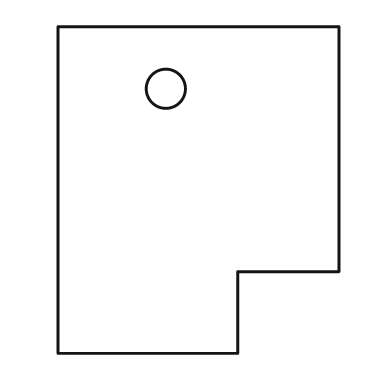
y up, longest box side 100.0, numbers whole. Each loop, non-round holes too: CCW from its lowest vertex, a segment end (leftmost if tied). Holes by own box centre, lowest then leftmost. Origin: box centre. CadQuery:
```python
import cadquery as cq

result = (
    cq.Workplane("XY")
    .moveTo(-43.0, -50.0)
    .lineTo(12.0, -50.0)
    .lineTo(12.0, -25.0)
    .lineTo(43.0, -25.0)
    .lineTo(43.0, 50.0)
    .lineTo(-43.0, 50.0)
    .close()
    .moveTo(-10.0, 31.0)
    .circle(6.0)
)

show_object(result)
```